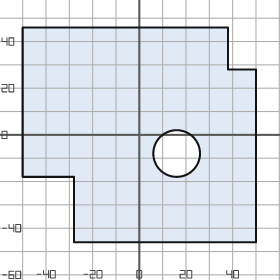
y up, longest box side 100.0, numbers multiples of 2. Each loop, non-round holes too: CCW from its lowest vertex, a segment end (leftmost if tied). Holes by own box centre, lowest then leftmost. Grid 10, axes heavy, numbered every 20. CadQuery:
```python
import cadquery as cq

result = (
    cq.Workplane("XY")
    .moveTo(-28.0, -46.0)
    .lineTo(50.0, -46.0)
    .lineTo(50.0, 28.0)
    .lineTo(38.0, 28.0)
    .lineTo(38.0, 46.0)
    .lineTo(-50.0, 46.0)
    .lineTo(-50.0, -18.0)
    .lineTo(-28.0, -18.0)
    .close()
    .moveTo(16.0, -8.0)
    .circle(10.0)
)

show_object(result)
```